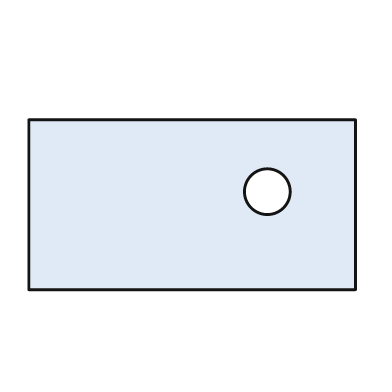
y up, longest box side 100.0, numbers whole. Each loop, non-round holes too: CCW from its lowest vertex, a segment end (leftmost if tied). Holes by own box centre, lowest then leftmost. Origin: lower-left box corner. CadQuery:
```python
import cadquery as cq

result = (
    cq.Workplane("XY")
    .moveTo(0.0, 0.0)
    .lineTo(100.0, 0.0)
    .lineTo(100.0, 52.0)
    .lineTo(0.0, 52.0)
    .close()
    .moveTo(73.0, 30.0)
    .circle(7.0)
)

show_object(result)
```